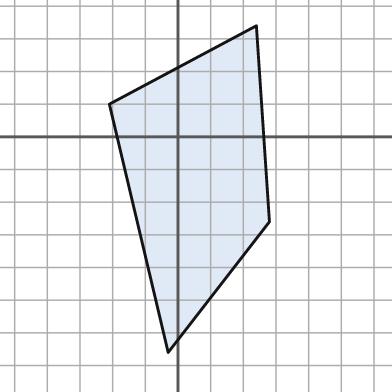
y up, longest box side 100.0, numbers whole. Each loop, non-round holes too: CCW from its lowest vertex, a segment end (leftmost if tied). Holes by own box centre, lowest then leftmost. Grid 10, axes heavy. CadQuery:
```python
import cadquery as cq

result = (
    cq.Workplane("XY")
    .moveTo(-3.0, -66.0)
    .lineTo(28.0, -26.0)
    .lineTo(24.0, 34.0)
    .lineTo(-21.0, 10.0)
    .close()
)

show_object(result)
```